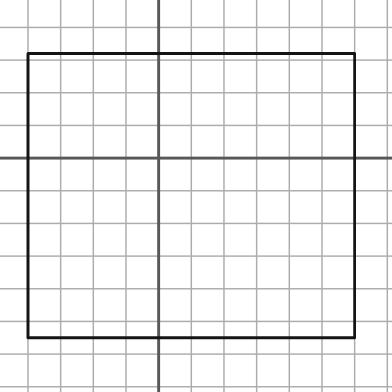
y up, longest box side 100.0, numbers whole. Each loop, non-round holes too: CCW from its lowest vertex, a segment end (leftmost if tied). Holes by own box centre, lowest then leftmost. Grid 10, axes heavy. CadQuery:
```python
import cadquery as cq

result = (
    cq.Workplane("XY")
    .moveTo(-40.0, -55.0)
    .lineTo(60.0, -55.0)
    .lineTo(60.0, 32.0)
    .lineTo(-40.0, 32.0)
    .close()
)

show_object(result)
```